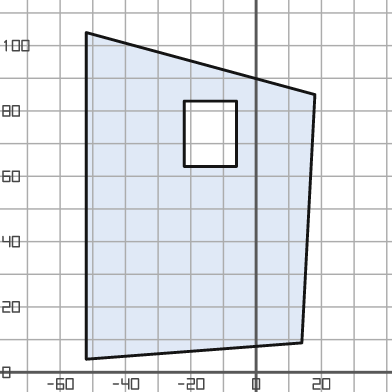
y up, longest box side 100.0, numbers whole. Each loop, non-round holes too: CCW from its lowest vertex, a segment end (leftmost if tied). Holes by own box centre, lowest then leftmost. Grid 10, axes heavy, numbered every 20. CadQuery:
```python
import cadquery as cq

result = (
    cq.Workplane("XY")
    .moveTo(-52.0, 4.0)
    .lineTo(14.0, 9.0)
    .lineTo(18.0, 85.0)
    .lineTo(-52.0, 104.0)
    .close()
    .moveTo(-22.0, 63.0)
    .lineTo(-6.0, 63.0)
    .lineTo(-6.0, 83.0)
    .lineTo(-22.0, 83.0)
    .close()
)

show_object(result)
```